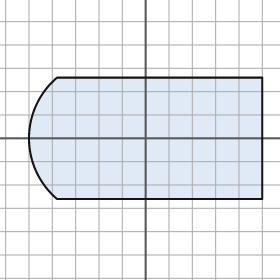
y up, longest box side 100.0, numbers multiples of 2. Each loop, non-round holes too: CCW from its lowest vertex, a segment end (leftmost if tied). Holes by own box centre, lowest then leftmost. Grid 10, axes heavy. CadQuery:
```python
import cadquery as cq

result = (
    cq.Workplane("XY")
    .moveTo(-38.0, -26.0)
    .lineTo(50.0, -26.0)
    .lineTo(50.0, 26.0)
    .lineTo(-38.0, 26.0)
    .threePointArc((-50.0, 0.0), (-38.0, -26.0))
    .close()
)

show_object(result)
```